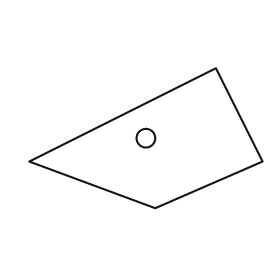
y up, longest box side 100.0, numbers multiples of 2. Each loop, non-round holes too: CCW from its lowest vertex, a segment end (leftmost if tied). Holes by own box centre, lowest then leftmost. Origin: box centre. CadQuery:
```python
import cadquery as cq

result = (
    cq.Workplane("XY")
    .moveTo(4.0, -30.0)
    .lineTo(50.0, -10.0)
    .lineTo(30.0, 30.0)
    .lineTo(-50.0, -10.0)
    .close()
    .moveTo(0.0, 0.0)
    .circle(4.0)
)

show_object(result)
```